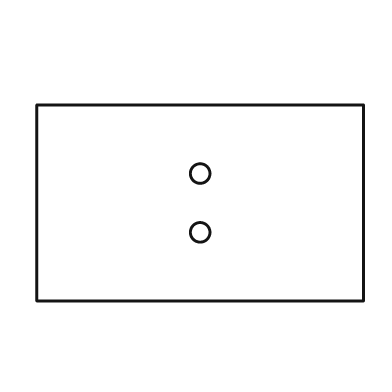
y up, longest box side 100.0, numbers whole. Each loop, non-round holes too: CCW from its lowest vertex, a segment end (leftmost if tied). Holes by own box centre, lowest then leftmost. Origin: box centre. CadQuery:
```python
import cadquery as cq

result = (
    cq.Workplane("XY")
    .moveTo(-50.0, -30.0)
    .lineTo(50.0, -30.0)
    .lineTo(50.0, 30.0)
    .lineTo(-50.0, 30.0)
    .close()
    .moveTo(0.0, -9.0)
    .circle(3.0)
    .moveTo(0.0, 9.0)
    .circle(3.0)
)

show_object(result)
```